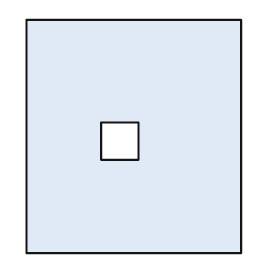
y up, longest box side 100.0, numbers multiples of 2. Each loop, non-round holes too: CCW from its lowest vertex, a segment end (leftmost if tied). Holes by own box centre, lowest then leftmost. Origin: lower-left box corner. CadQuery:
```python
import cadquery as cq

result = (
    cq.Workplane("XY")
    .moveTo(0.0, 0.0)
    .lineTo(92.0, 0.0)
    .lineTo(92.0, 100.0)
    .lineTo(0.0, 100.0)
    .close()
    .moveTo(32.0, 40.0)
    .lineTo(48.0, 40.0)
    .lineTo(48.0, 56.0)
    .lineTo(32.0, 56.0)
    .close()
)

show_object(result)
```